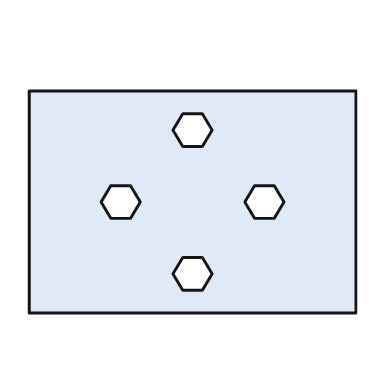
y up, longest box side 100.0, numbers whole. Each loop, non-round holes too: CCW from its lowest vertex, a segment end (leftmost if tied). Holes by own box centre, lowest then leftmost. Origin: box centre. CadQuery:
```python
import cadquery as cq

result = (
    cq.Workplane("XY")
    .moveTo(-50.0, -34.0)
    .lineTo(50.0, -34.0)
    .lineTo(50.0, 34.0)
    .lineTo(-50.0, 34.0)
    .close()
    .moveTo(-3.0, -27.0)
    .lineTo(3.0, -27.0)
    .lineTo(6.0, -22.0)
    .lineTo(3.0, -17.0)
    .lineTo(-3.0, -17.0)
    .lineTo(-6.0, -22.0)
    .close()
    .moveTo(-25.0, -5.0)
    .lineTo(-19.0, -5.0)
    .lineTo(-16.0, 0.0)
    .lineTo(-19.0, 5.0)
    .lineTo(-25.0, 5.0)
    .lineTo(-28.0, 0.0)
    .close()
    .moveTo(19.0, -5.0)
    .lineTo(25.0, -5.0)
    .lineTo(28.0, 0.0)
    .lineTo(25.0, 5.0)
    .lineTo(19.0, 5.0)
    .lineTo(16.0, 0.0)
    .close()
    .moveTo(-3.0, 17.0)
    .lineTo(3.0, 17.0)
    .lineTo(6.0, 22.0)
    .lineTo(3.0, 27.0)
    .lineTo(-3.0, 27.0)
    .lineTo(-6.0, 22.0)
    .close()
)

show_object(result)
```